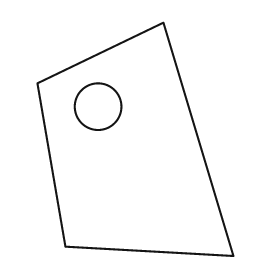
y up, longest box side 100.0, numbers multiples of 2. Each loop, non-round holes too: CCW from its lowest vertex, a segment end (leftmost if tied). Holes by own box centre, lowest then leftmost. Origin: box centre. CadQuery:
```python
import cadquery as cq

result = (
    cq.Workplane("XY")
    .moveTo(42.0, -50.0)
    .lineTo(12.0, 50.0)
    .lineTo(-42.0, 24.0)
    .lineTo(-30.0, -46.0)
    .close()
    .moveTo(-16.0, 14.0)
    .circle(10.0)
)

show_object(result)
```